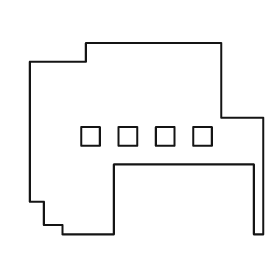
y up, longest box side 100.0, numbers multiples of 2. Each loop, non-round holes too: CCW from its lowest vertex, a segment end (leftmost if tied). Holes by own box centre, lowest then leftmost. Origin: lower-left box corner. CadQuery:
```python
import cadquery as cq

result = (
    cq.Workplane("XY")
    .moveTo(14.0, 0.0)
    .lineTo(36.0, 0.0)
    .lineTo(36.0, 30.0)
    .lineTo(96.0, 30.0)
    .lineTo(96.0, 0.0)
    .lineTo(100.0, 0.0)
    .lineTo(100.0, 50.0)
    .lineTo(82.0, 50.0)
    .lineTo(82.0, 82.0)
    .lineTo(24.0, 82.0)
    .lineTo(24.0, 74.0)
    .lineTo(0.0, 74.0)
    .lineTo(0.0, 14.0)
    .lineTo(6.0, 14.0)
    .lineTo(6.0, 4.0)
    .lineTo(14.0, 4.0)
    .close()
    .moveTo(22.0, 38.0)
    .lineTo(30.0, 38.0)
    .lineTo(30.0, 46.0)
    .lineTo(22.0, 46.0)
    .close()
    .moveTo(38.0, 38.0)
    .lineTo(46.0, 38.0)
    .lineTo(46.0, 46.0)
    .lineTo(38.0, 46.0)
    .close()
    .moveTo(54.0, 38.0)
    .lineTo(62.0, 38.0)
    .lineTo(62.0, 46.0)
    .lineTo(54.0, 46.0)
    .close()
    .moveTo(70.0, 38.0)
    .lineTo(78.0, 38.0)
    .lineTo(78.0, 46.0)
    .lineTo(70.0, 46.0)
    .close()
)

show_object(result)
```